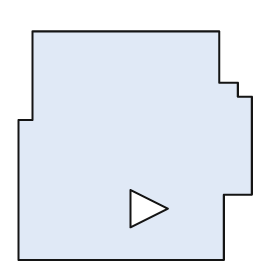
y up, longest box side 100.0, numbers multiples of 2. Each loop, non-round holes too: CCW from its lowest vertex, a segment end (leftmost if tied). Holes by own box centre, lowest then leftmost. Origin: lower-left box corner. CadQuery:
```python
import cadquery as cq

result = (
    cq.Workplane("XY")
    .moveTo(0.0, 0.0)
    .lineTo(88.0, 0.0)
    .lineTo(88.0, 28.0)
    .lineTo(100.0, 28.0)
    .lineTo(100.0, 70.0)
    .lineTo(94.0, 70.0)
    .lineTo(94.0, 76.0)
    .lineTo(86.0, 76.0)
    .lineTo(86.0, 98.0)
    .lineTo(6.0, 98.0)
    .lineTo(6.0, 60.0)
    .lineTo(0.0, 60.0)
    .close()
    .moveTo(48.0, 14.0)
    .lineTo(64.0, 22.0)
    .lineTo(48.0, 30.0)
    .close()
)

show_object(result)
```